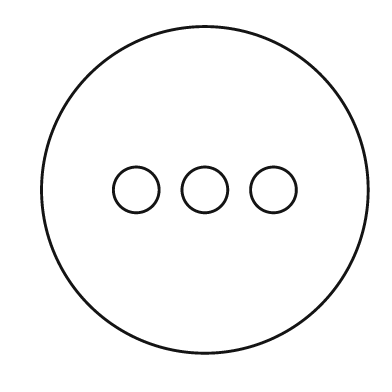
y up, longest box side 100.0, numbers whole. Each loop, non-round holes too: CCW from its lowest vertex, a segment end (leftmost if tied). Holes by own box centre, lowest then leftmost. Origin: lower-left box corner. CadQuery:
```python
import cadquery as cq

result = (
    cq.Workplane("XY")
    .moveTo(50.0, 50.0)
    .circle(50.0)
    .moveTo(29.0, 50.0)
    .circle(7.0)
    .moveTo(50.0, 50.0)
    .circle(7.0)
    .moveTo(71.0, 50.0)
    .circle(7.0)
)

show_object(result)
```